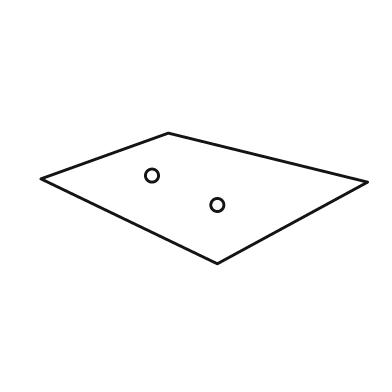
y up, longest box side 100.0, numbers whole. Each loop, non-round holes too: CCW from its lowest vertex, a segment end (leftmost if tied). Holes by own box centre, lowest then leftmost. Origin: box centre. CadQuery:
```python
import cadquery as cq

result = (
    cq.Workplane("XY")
    .moveTo(4.0, -20.0)
    .lineTo(50.0, 5.0)
    .lineTo(-11.0, 20.0)
    .lineTo(-50.0, 6.0)
    .close()
    .moveTo(4.0, -2.0)
    .circle(2.0)
    .moveTo(-16.0, 7.0)
    .circle(2.0)
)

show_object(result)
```